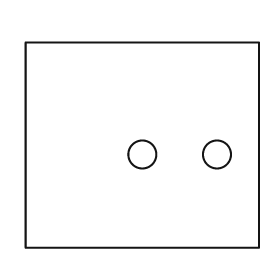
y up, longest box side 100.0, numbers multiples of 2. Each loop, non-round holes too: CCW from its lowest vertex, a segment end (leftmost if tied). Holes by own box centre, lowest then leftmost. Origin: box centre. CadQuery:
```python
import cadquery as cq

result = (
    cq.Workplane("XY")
    .moveTo(-50.0, -44.0)
    .lineTo(50.0, -44.0)
    .lineTo(50.0, 44.0)
    .lineTo(-50.0, 44.0)
    .close()
    .moveTo(0.0, -4.0)
    .circle(6.0)
    .moveTo(32.0, -4.0)
    .circle(6.0)
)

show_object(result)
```